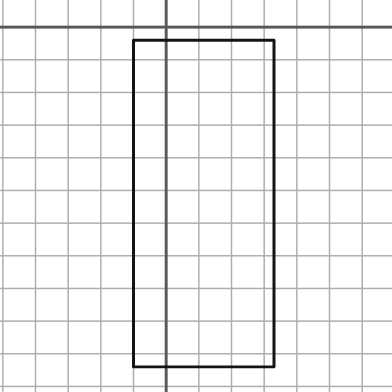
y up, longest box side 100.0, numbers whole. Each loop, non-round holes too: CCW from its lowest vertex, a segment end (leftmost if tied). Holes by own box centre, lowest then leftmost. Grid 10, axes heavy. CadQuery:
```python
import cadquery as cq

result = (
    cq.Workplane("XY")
    .moveTo(-10.0, -104.0)
    .lineTo(33.0, -104.0)
    .lineTo(33.0, -4.0)
    .lineTo(-10.0, -4.0)
    .close()
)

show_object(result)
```